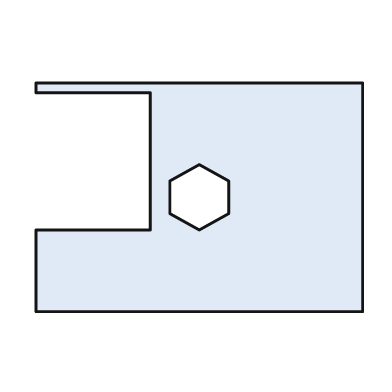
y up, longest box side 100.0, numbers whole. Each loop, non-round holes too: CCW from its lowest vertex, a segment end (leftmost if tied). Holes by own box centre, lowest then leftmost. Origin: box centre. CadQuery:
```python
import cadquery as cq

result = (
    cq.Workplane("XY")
    .moveTo(-50.0, -35.0)
    .lineTo(50.0, -35.0)
    .lineTo(50.0, 35.0)
    .lineTo(-50.0, 35.0)
    .lineTo(-50.0, 32.0)
    .lineTo(-15.0, 32.0)
    .lineTo(-15.0, -10.0)
    .lineTo(-50.0, -10.0)
    .close()
    .moveTo(0.0, -10.0)
    .lineTo(9.0, -5.0)
    .lineTo(9.0, 5.0)
    .lineTo(0.0, 10.0)
    .lineTo(-9.0, 5.0)
    .lineTo(-9.0, -5.0)
    .close()
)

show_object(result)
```